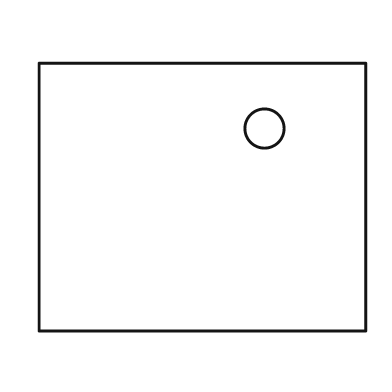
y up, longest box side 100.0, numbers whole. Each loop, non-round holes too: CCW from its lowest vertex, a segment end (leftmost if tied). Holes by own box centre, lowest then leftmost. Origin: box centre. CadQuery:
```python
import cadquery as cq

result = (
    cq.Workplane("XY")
    .moveTo(-50.0, -41.0)
    .lineTo(50.0, -41.0)
    .lineTo(50.0, 41.0)
    .lineTo(-50.0, 41.0)
    .close()
    .moveTo(19.0, 21.0)
    .circle(6.0)
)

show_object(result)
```